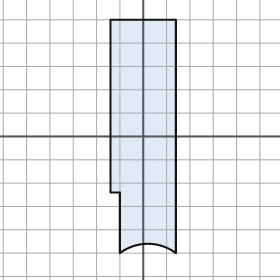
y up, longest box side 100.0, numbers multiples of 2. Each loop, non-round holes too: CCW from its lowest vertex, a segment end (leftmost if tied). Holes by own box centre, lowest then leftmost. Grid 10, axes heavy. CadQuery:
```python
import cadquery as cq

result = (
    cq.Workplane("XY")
    .moveTo(-10.0, -50.0)
    .threePointArc((2.0, -46.0), (14.0, -50.0))
    .lineTo(14.0, 50.0)
    .lineTo(-14.0, 50.0)
    .lineTo(-14.0, -24.0)
    .lineTo(-10.0, -24.0)
    .close()
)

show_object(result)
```